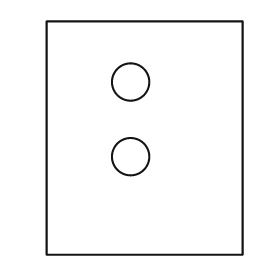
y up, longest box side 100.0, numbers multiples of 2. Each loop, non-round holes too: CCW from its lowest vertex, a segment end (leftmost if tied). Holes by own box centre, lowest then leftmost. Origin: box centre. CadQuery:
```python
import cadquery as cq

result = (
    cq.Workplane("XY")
    .moveTo(-42.0, -50.0)
    .lineTo(42.0, -50.0)
    .lineTo(42.0, 50.0)
    .lineTo(-42.0, 50.0)
    .close()
    .moveTo(-6.0, -8.0)
    .circle(8.0)
    .moveTo(-6.0, 24.0)
    .circle(8.0)
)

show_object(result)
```